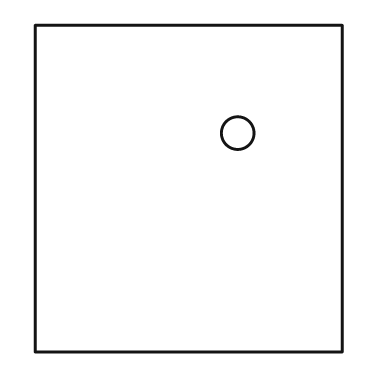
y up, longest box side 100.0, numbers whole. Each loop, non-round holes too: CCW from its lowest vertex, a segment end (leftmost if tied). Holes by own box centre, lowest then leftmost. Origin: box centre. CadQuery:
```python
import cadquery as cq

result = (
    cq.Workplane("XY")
    .moveTo(-47.0, -50.0)
    .lineTo(47.0, -50.0)
    .lineTo(47.0, 50.0)
    .lineTo(-47.0, 50.0)
    .close()
    .moveTo(15.0, 17.0)
    .circle(5.0)
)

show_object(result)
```